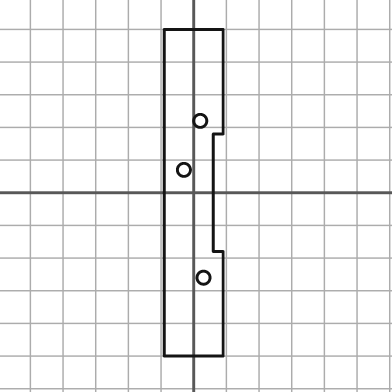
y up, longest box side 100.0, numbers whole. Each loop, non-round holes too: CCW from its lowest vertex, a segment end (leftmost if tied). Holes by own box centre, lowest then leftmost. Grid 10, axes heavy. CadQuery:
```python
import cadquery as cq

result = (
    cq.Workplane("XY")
    .moveTo(-9.0, -50.0)
    .lineTo(9.0, -50.0)
    .lineTo(9.0, -18.0)
    .lineTo(6.0, -18.0)
    .lineTo(6.0, 18.0)
    .lineTo(9.0, 18.0)
    .lineTo(9.0, 50.0)
    .lineTo(-9.0, 50.0)
    .close()
    .moveTo(3.0, -26.0)
    .circle(2.0)
    .moveTo(-3.0, 7.0)
    .circle(2.0)
    .moveTo(2.0, 22.0)
    .circle(2.0)
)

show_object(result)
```